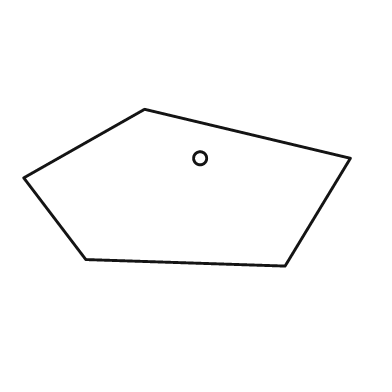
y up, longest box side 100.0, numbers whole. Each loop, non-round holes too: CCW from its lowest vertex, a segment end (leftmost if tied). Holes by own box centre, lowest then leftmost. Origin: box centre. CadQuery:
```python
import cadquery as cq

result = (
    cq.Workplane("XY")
    .moveTo(30.0, -24.0)
    .lineTo(50.0, 9.0)
    .lineTo(-13.0, 24.0)
    .lineTo(-50.0, 3.0)
    .lineTo(-31.0, -22.0)
    .close()
    .moveTo(4.0, 9.0)
    .circle(2.0)
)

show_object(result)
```